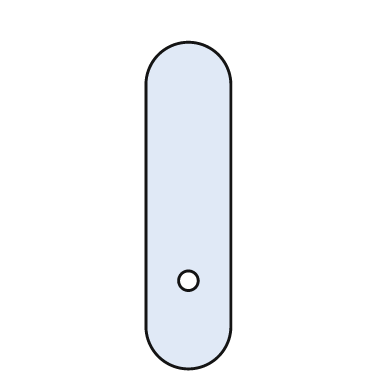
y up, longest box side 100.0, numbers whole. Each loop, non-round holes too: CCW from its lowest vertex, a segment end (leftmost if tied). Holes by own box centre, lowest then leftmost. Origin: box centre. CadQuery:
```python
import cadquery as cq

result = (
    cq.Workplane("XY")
    .moveTo(-13.0, -37.0)
    .threePointArc((0.0, -50.0), (13.0, -37.0))
    .lineTo(13.0, 37.0)
    .threePointArc((0.0, 50.0), (-13.0, 37.0))
    .close()
    .moveTo(0.0, -23.0)
    .circle(3.0)
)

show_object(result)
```